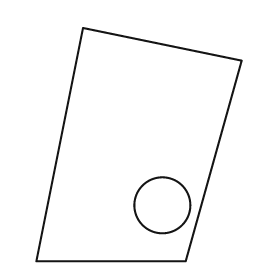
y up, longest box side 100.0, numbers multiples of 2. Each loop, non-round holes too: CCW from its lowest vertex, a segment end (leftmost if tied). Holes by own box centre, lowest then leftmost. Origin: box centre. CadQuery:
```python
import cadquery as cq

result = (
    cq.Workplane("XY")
    .moveTo(-44.0, -50.0)
    .lineTo(20.0, -50.0)
    .lineTo(44.0, 36.0)
    .lineTo(-24.0, 50.0)
    .close()
    .moveTo(10.0, -26.0)
    .circle(12.0)
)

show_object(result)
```